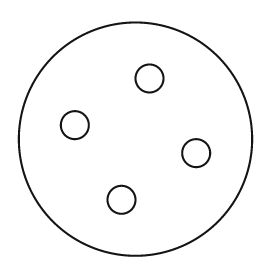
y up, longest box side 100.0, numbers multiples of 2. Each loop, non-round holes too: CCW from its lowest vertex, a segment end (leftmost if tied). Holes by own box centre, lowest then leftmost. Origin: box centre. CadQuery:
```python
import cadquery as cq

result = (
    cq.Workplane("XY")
    .moveTo(0.0, 0.0)
    .circle(50.0)
    .moveTo(-6.0, -26.0)
    .circle(6.0)
    .moveTo(26.0, -6.0)
    .circle(6.0)
    .moveTo(-26.0, 6.0)
    .circle(6.0)
    .moveTo(6.0, 26.0)
    .circle(6.0)
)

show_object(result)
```